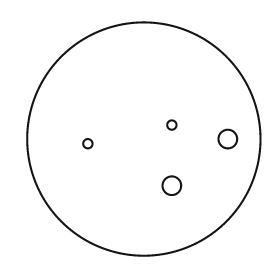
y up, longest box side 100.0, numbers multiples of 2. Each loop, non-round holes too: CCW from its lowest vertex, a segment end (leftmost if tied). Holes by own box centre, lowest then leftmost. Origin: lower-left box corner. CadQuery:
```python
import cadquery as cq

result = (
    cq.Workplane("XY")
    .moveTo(50.0, 50.0)
    .circle(50.0)
    .moveTo(62.0, 30.0)
    .circle(4.0)
    .moveTo(26.0, 48.0)
    .circle(2.0)
    .moveTo(86.0, 50.0)
    .circle(4.0)
    .moveTo(62.0, 56.0)
    .circle(2.0)
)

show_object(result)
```